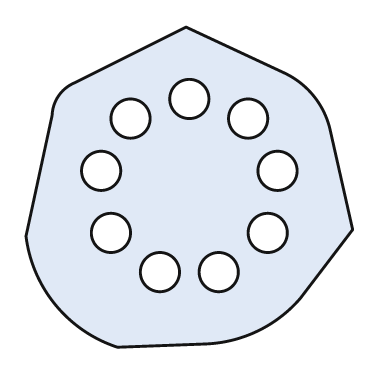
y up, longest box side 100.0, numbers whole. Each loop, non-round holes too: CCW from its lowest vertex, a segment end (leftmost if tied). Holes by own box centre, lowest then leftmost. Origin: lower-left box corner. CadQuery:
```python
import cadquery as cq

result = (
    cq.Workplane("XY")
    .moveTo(28.0, 0.0)
    .lineTo(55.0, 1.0)
    .threePointArc((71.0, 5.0), (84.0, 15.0))
    .lineTo(100.0, 36.0)
    .lineTo(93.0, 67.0)
    .threePointArc((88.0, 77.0), (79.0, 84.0))
    .lineTo(49.0, 98.0)
    .lineTo(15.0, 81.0)
    .threePointArc((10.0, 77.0), (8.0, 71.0))
    .lineTo(0.0, 34.0)
    .threePointArc((9.0, 13.0), (28.0, 0.0))
    .close()
    .moveTo(41.0, 23.0)
    .circle(6.0)
    .moveTo(59.0, 23.0)
    .circle(6.0)
    .moveTo(26.0, 35.0)
    .circle(6.0)
    .moveTo(74.0, 35.0)
    .circle(6.0)
    .moveTo(23.0, 54.0)
    .circle(6.0)
    .moveTo(77.0, 54.0)
    .circle(6.0)
    .moveTo(32.0, 70.0)
    .circle(6.0)
    .moveTo(68.0, 70.0)
    .circle(6.0)
    .moveTo(50.0, 76.0)
    .circle(6.0)
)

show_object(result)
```